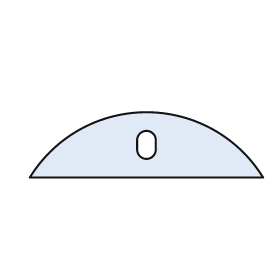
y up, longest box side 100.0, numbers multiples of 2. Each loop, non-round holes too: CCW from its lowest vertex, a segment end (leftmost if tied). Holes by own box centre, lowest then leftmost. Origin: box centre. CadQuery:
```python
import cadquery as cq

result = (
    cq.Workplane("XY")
    .moveTo(-50.0, -14.0)
    .lineTo(50.0, -14.0)
    .threePointArc((0.0, 14.0), (-50.0, -14.0))
    .close()
    .moveTo(-4.0, -2.0)
    .threePointArc((0.0, -6.0), (4.0, -2.0))
    .lineTo(4.0, 2.0)
    .threePointArc((0.0, 6.0), (-4.0, 2.0))
    .close()
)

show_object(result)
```